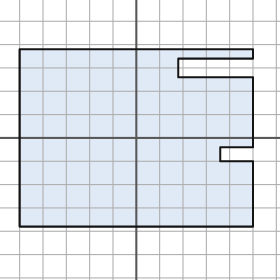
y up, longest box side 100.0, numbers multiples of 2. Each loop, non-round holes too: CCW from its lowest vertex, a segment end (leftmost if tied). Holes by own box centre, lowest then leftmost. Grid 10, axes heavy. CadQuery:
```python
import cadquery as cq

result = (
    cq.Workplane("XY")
    .moveTo(-50.0, -38.0)
    .lineTo(50.0, -38.0)
    .lineTo(50.0, -10.0)
    .lineTo(36.0, -10.0)
    .lineTo(36.0, -4.0)
    .lineTo(50.0, -4.0)
    .lineTo(50.0, 26.0)
    .lineTo(18.0, 26.0)
    .lineTo(18.0, 34.0)
    .lineTo(50.0, 34.0)
    .lineTo(50.0, 38.0)
    .lineTo(-50.0, 38.0)
    .close()
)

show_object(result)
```